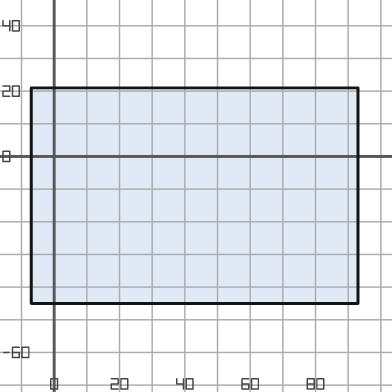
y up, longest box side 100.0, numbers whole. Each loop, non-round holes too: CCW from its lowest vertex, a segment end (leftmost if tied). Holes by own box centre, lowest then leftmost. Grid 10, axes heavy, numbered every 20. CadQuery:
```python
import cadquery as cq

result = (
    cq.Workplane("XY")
    .moveTo(-7.0, -45.0)
    .lineTo(93.0, -45.0)
    .lineTo(93.0, 21.0)
    .lineTo(-7.0, 21.0)
    .close()
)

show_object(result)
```